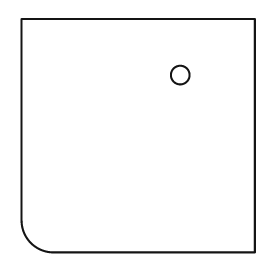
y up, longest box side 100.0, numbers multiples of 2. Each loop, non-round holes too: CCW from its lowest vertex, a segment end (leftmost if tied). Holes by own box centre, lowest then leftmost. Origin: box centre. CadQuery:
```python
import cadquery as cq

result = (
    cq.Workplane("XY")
    .moveTo(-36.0, -50.0)
    .lineTo(50.0, -50.0)
    .lineTo(50.0, 50.0)
    .lineTo(-50.0, 50.0)
    .lineTo(-50.0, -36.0)
    .threePointArc((-46.0, -46.0), (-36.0, -50.0))
    .close()
    .moveTo(18.0, 26.0)
    .circle(4.0)
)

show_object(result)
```